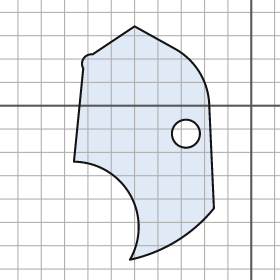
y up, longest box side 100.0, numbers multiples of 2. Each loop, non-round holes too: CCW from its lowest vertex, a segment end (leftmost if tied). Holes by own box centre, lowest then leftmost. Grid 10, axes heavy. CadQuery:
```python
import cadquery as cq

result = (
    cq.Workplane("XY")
    .moveTo(-52.0, -66.0)
    .threePointArc((-32.0, -58.0), (-16.0, -44.0))
    .lineTo(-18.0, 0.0)
    .threePointArc((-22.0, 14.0), (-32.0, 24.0))
    .lineTo(-50.0, 34.0)
    .lineTo(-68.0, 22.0)
    .threePointArc((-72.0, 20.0), (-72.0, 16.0))
    .lineTo(-76.0, -24.0)
    .threePointArc((-52.0, -38.0), (-52.0, -66.0))
    .close()
    .moveTo(-28.0, -12.0)
    .circle(6.0)
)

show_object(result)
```